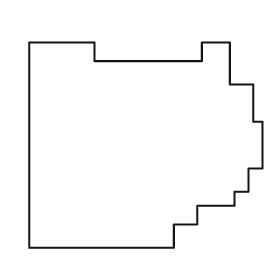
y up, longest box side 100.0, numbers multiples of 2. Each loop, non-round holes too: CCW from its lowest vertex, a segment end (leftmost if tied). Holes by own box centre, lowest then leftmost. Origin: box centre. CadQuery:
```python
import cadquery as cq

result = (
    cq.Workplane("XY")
    .moveTo(-50.0, -44.0)
    .lineTo(12.0, -44.0)
    .lineTo(12.0, -34.0)
    .lineTo(22.0, -34.0)
    .lineTo(22.0, -26.0)
    .lineTo(38.0, -26.0)
    .lineTo(38.0, -20.0)
    .lineTo(44.0, -20.0)
    .lineTo(44.0, -10.0)
    .lineTo(50.0, -10.0)
    .lineTo(50.0, 10.0)
    .lineTo(46.0, 10.0)
    .lineTo(46.0, 26.0)
    .lineTo(36.0, 26.0)
    .lineTo(36.0, 44.0)
    .lineTo(24.0, 44.0)
    .lineTo(24.0, 36.0)
    .lineTo(-22.0, 36.0)
    .lineTo(-22.0, 44.0)
    .lineTo(-50.0, 44.0)
    .close()
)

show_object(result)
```